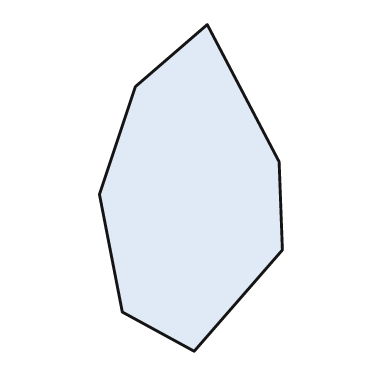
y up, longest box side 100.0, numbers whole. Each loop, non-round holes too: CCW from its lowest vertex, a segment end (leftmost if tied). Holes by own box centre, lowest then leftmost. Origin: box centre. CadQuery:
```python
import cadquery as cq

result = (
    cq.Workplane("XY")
    .moveTo(1.0, -50.0)
    .lineTo(28.0, -19.0)
    .lineTo(27.0, 8.0)
    .lineTo(5.0, 50.0)
    .lineTo(-17.0, 31.0)
    .lineTo(-28.0, -2.0)
    .lineTo(-21.0, -38.0)
    .close()
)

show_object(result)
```